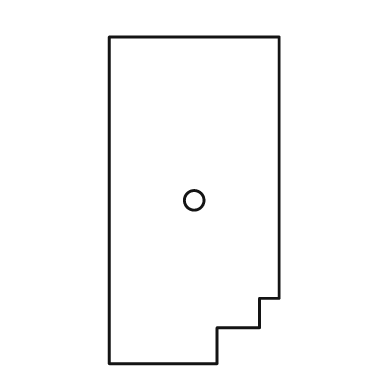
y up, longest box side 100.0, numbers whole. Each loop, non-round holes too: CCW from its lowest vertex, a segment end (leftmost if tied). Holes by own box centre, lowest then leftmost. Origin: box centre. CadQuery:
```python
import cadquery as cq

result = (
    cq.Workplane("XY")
    .moveTo(-26.0, -50.0)
    .lineTo(7.0, -50.0)
    .lineTo(7.0, -39.0)
    .lineTo(20.0, -39.0)
    .lineTo(20.0, -30.0)
    .lineTo(26.0, -30.0)
    .lineTo(26.0, 50.0)
    .lineTo(-26.0, 50.0)
    .close()
    .moveTo(0.0, 0.0)
    .circle(3.0)
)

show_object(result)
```